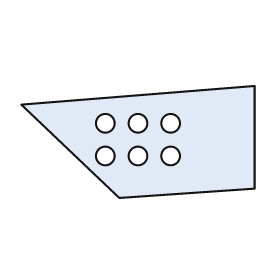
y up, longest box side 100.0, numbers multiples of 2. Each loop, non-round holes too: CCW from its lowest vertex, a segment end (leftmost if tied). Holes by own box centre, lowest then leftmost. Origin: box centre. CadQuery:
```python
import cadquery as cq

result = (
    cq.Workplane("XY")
    .moveTo(-8.0, -24.0)
    .lineTo(50.0, -20.0)
    .lineTo(50.0, 24.0)
    .lineTo(-50.0, 16.0)
    .close()
    .moveTo(-14.0, -6.0)
    .circle(4.0)
    .moveTo(0.0, -6.0)
    .circle(4.0)
    .moveTo(14.0, -6.0)
    .circle(4.0)
    .moveTo(-14.0, 8.0)
    .circle(4.0)
    .moveTo(0.0, 8.0)
    .circle(4.0)
    .moveTo(14.0, 8.0)
    .circle(4.0)
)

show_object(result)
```